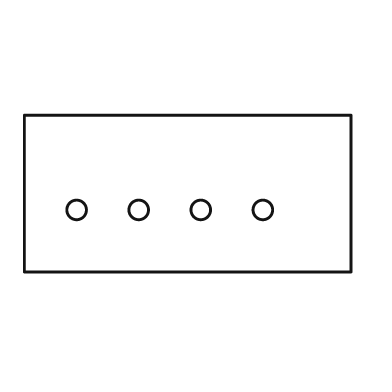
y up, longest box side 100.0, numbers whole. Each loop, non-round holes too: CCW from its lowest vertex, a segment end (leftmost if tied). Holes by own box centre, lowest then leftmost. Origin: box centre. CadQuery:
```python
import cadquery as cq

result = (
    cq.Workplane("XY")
    .moveTo(-50.0, -24.0)
    .lineTo(50.0, -24.0)
    .lineTo(50.0, 24.0)
    .lineTo(-50.0, 24.0)
    .close()
    .moveTo(-34.0, -5.0)
    .circle(3.0)
    .moveTo(-15.0, -5.0)
    .circle(3.0)
    .moveTo(4.0, -5.0)
    .circle(3.0)
    .moveTo(23.0, -5.0)
    .circle(3.0)
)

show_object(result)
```